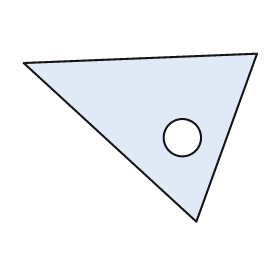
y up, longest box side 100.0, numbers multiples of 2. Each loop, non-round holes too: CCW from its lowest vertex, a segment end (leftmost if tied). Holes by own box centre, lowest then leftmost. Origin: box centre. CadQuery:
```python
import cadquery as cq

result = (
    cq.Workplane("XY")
    .moveTo(24.0, -36.0)
    .lineTo(50.0, 36.0)
    .lineTo(-50.0, 32.0)
    .close()
    .moveTo(18.0, 0.0)
    .circle(8.0)
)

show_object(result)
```